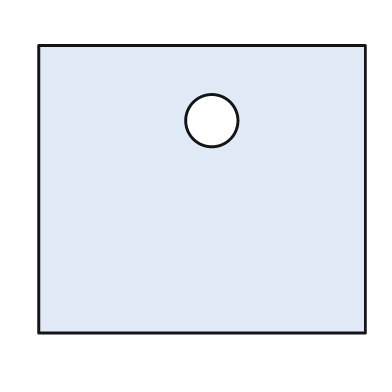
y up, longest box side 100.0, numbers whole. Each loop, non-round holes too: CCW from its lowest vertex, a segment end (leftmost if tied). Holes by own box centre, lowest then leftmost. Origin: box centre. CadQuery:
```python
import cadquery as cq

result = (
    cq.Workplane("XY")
    .moveTo(-50.0, -44.0)
    .lineTo(50.0, -44.0)
    .lineTo(50.0, 44.0)
    .lineTo(-50.0, 44.0)
    .close()
    .moveTo(3.0, 21.0)
    .circle(8.0)
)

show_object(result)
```